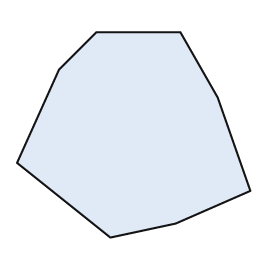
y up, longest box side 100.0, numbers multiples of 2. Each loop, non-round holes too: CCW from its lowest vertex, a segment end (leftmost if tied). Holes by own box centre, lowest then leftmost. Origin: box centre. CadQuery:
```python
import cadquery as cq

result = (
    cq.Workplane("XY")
    .moveTo(-10.0, -44.0)
    .lineTo(18.0, -38.0)
    .lineTo(50.0, -24.0)
    .lineTo(36.0, 16.0)
    .lineTo(20.0, 44.0)
    .lineTo(-16.0, 44.0)
    .lineTo(-32.0, 28.0)
    .lineTo(-50.0, -12.0)
    .close()
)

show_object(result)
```